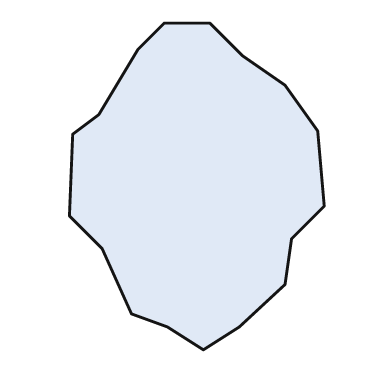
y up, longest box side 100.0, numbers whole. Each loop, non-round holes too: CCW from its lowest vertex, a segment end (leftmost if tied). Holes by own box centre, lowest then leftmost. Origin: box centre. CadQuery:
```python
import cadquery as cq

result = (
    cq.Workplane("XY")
    .moveTo(2.0, -50.0)
    .lineTo(13.0, -43.0)
    .lineTo(27.0, -30.0)
    .lineTo(29.0, -16.0)
    .lineTo(39.0, -6.0)
    .lineTo(37.0, 17.0)
    .lineTo(27.0, 31.0)
    .lineTo(14.0, 40.0)
    .lineTo(4.0, 50.0)
    .lineTo(-10.0, 50.0)
    .lineTo(-18.0, 42.0)
    .lineTo(-30.0, 22.0)
    .lineTo(-38.0, 16.0)
    .lineTo(-39.0, -9.0)
    .lineTo(-29.0, -19.0)
    .lineTo(-20.0, -39.0)
    .lineTo(-9.0, -43.0)
    .close()
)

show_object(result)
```